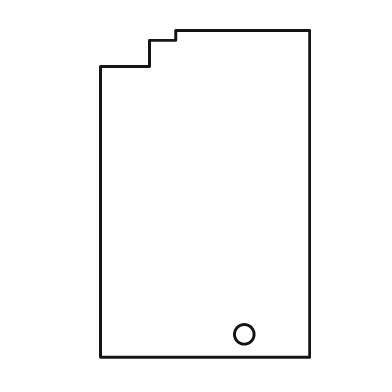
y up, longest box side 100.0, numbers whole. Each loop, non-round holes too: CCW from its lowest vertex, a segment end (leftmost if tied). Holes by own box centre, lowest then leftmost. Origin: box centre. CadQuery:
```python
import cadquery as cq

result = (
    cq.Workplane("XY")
    .moveTo(-32.0, -50.0)
    .lineTo(32.0, -50.0)
    .lineTo(32.0, 50.0)
    .lineTo(-9.0, 50.0)
    .lineTo(-9.0, 47.0)
    .lineTo(-17.0, 47.0)
    .lineTo(-17.0, 39.0)
    .lineTo(-32.0, 39.0)
    .close()
    .moveTo(12.0, -43.0)
    .circle(3.0)
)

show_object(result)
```